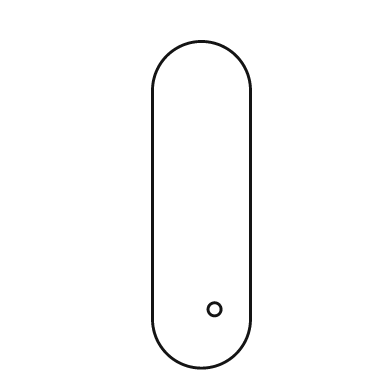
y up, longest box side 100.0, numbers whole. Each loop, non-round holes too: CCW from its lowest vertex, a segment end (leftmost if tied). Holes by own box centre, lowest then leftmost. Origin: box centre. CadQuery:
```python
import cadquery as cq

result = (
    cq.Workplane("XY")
    .moveTo(-15.0, -35.0)
    .threePointArc((0.0, -50.0), (15.0, -35.0))
    .lineTo(15.0, 35.0)
    .threePointArc((0.0, 50.0), (-15.0, 35.0))
    .close()
    .moveTo(4.0, -32.0)
    .circle(2.0)
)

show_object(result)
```